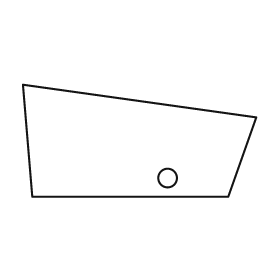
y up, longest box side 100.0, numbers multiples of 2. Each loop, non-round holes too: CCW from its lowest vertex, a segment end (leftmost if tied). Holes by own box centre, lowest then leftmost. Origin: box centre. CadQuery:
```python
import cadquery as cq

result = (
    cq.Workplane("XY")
    .moveTo(-46.0, -24.0)
    .lineTo(38.0, -24.0)
    .lineTo(50.0, 10.0)
    .lineTo(-50.0, 24.0)
    .close()
    .moveTo(12.0, -16.0)
    .circle(4.0)
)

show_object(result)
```